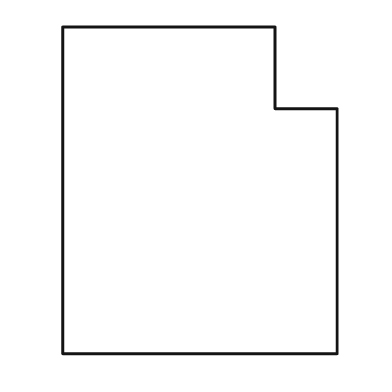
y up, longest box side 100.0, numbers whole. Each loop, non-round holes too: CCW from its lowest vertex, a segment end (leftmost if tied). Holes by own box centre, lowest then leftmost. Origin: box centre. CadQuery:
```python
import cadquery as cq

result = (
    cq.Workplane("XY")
    .moveTo(-42.0, -50.0)
    .lineTo(42.0, -50.0)
    .lineTo(42.0, 25.0)
    .lineTo(23.0, 25.0)
    .lineTo(23.0, 50.0)
    .lineTo(-42.0, 50.0)
    .close()
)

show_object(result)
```